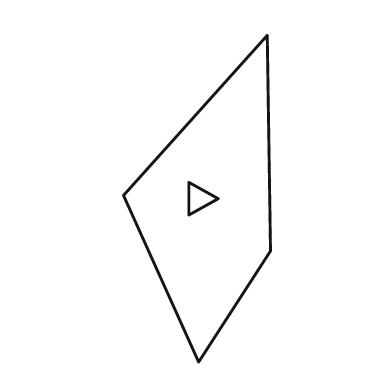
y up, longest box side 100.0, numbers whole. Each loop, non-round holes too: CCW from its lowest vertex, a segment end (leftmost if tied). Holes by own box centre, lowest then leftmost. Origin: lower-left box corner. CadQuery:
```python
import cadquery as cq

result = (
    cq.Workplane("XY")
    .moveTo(23.0, 0.0)
    .lineTo(45.0, 34.0)
    .lineTo(44.0, 100.0)
    .lineTo(0.0, 51.0)
    .close()
    .moveTo(20.0, 45.0)
    .lineTo(29.0, 50.0)
    .lineTo(20.0, 55.0)
    .close()
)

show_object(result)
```